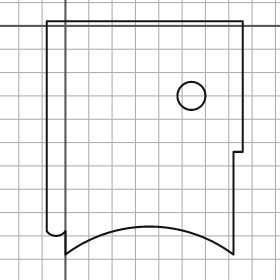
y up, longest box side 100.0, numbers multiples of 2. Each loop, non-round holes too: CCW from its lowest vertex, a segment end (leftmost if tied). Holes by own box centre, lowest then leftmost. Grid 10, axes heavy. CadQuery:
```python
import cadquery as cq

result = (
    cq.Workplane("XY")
    .moveTo(0.0, -98.0)
    .threePointArc((36.0, -86.0), (72.0, -98.0))
    .lineTo(72.0, -54.0)
    .lineTo(76.0, -54.0)
    .lineTo(76.0, 2.0)
    .lineTo(-8.0, 2.0)
    .lineTo(-8.0, -88.0)
    .threePointArc((-4.0, -90.0), (0.0, -88.0))
    .close()
    .moveTo(54.0, -30.0)
    .circle(6.0)
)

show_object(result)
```